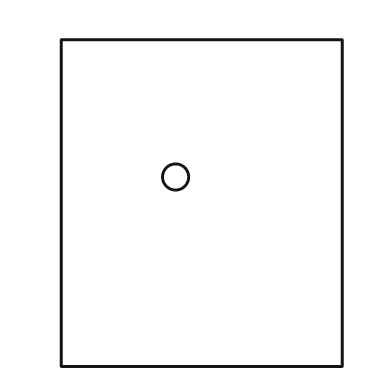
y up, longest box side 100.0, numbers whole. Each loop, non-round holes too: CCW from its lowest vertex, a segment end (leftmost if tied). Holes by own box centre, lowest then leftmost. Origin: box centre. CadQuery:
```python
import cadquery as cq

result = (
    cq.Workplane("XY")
    .moveTo(-43.0, -50.0)
    .lineTo(43.0, -50.0)
    .lineTo(43.0, 50.0)
    .lineTo(-43.0, 50.0)
    .close()
    .moveTo(-8.0, 8.0)
    .circle(4.0)
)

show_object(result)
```